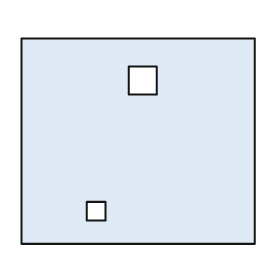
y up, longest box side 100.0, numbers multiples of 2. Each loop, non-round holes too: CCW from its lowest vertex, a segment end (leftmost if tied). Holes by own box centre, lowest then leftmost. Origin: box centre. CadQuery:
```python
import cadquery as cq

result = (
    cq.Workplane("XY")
    .moveTo(-50.0, -44.0)
    .lineTo(50.0, -44.0)
    .lineTo(50.0, 44.0)
    .lineTo(-50.0, 44.0)
    .close()
    .moveTo(-22.0, -34.0)
    .lineTo(-14.0, -34.0)
    .lineTo(-14.0, -26.0)
    .lineTo(-22.0, -26.0)
    .close()
    .moveTo(-4.0, 20.0)
    .lineTo(8.0, 20.0)
    .lineTo(8.0, 32.0)
    .lineTo(-4.0, 32.0)
    .close()
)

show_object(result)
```